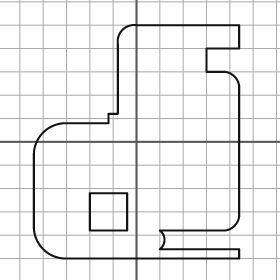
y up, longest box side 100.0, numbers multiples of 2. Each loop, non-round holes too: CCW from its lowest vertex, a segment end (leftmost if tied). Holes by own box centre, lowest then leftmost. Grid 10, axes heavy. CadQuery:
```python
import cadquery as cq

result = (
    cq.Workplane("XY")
    .moveTo(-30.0, -50.0)
    .lineTo(44.0, -50.0)
    .lineTo(44.0, -46.0)
    .lineTo(10.0, -46.0)
    .threePointArc((12.0, -42.0), (10.0, -38.0))
    .lineTo(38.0, -38.0)
    .threePointArc((42.0, -36.0), (44.0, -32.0))
    .lineTo(44.0, 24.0)
    .threePointArc((42.0, 28.0), (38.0, 30.0))
    .lineTo(30.0, 30.0)
    .lineTo(30.0, 40.0)
    .lineTo(44.0, 40.0)
    .lineTo(44.0, 50.0)
    .lineTo(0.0, 50.0)
    .threePointArc((-6.0, 48.0), (-8.0, 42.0))
    .lineTo(-8.0, 12.0)
    .lineTo(-12.0, 12.0)
    .lineTo(-12.0, 8.0)
    .lineTo(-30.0, 8.0)
    .threePointArc((-40.0, 4.0), (-44.0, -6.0))
    .lineTo(-44.0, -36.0)
    .threePointArc((-40.0, -46.0), (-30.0, -50.0))
    .close()
    .moveTo(-20.0, -38.0)
    .lineTo(-4.0, -38.0)
    .lineTo(-4.0, -22.0)
    .lineTo(-20.0, -22.0)
    .close()
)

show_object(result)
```